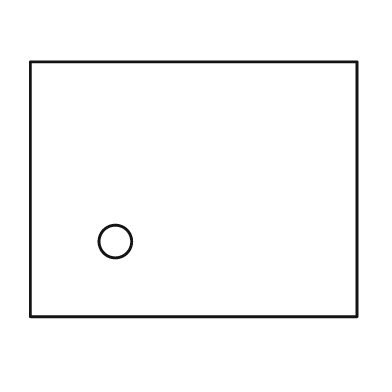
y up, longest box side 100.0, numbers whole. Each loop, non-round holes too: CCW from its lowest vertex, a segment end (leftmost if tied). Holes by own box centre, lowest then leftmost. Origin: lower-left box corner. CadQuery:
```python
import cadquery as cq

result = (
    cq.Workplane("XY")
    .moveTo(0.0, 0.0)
    .lineTo(100.0, 0.0)
    .lineTo(100.0, 78.0)
    .lineTo(0.0, 78.0)
    .close()
    .moveTo(26.0, 23.0)
    .circle(5.0)
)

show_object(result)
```